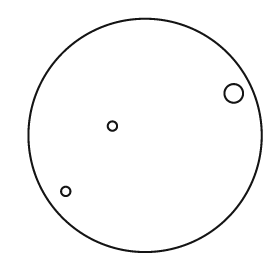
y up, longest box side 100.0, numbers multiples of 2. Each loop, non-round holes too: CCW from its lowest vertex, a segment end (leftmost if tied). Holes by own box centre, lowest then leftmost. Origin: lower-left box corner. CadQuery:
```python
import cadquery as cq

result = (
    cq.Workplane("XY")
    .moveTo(50.0, 50.0)
    .circle(50.0)
    .moveTo(16.0, 26.0)
    .circle(2.0)
    .moveTo(36.0, 54.0)
    .circle(2.0)
    .moveTo(88.0, 68.0)
    .circle(4.0)
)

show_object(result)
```